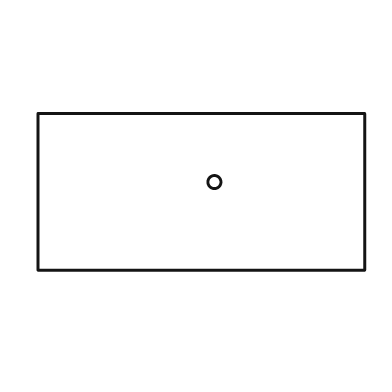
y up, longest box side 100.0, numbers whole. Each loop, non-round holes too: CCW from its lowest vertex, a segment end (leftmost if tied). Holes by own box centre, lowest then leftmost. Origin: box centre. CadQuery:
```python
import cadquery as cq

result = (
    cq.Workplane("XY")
    .moveTo(-50.0, -24.0)
    .lineTo(50.0, -24.0)
    .lineTo(50.0, 24.0)
    .lineTo(-50.0, 24.0)
    .close()
    .moveTo(4.0, 3.0)
    .circle(2.0)
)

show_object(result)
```